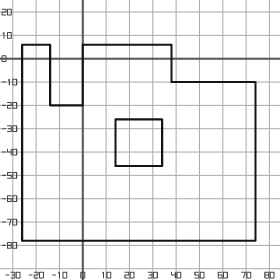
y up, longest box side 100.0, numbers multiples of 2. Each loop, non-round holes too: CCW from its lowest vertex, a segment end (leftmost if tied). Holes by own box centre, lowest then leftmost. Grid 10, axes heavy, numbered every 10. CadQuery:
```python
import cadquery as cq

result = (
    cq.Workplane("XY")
    .moveTo(-26.0, -78.0)
    .lineTo(74.0, -78.0)
    .lineTo(74.0, -10.0)
    .lineTo(38.0, -10.0)
    .lineTo(38.0, 6.0)
    .lineTo(0.0, 6.0)
    .lineTo(0.0, -20.0)
    .lineTo(-14.0, -20.0)
    .lineTo(-14.0, 6.0)
    .lineTo(-26.0, 6.0)
    .close()
    .moveTo(14.0, -46.0)
    .lineTo(34.0, -46.0)
    .lineTo(34.0, -26.0)
    .lineTo(14.0, -26.0)
    .close()
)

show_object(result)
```